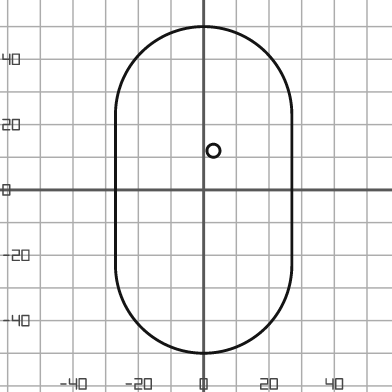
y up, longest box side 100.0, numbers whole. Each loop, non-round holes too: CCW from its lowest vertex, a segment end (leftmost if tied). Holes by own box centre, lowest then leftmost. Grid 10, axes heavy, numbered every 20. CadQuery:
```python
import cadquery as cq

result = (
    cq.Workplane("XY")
    .moveTo(-27.0, -23.0)
    .threePointArc((0.0, -50.0), (27.0, -23.0))
    .lineTo(27.0, 23.0)
    .threePointArc((0.0, 50.0), (-27.0, 23.0))
    .close()
    .moveTo(3.0, 12.0)
    .circle(2.0)
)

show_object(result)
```